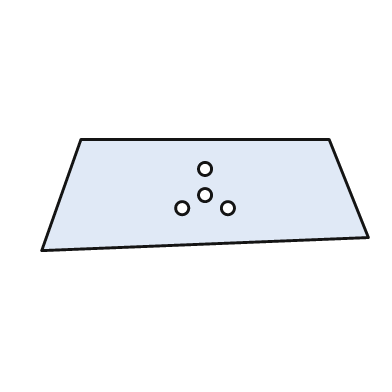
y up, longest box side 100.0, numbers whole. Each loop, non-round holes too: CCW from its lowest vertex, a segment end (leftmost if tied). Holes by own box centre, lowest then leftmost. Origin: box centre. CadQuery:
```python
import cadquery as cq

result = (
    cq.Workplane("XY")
    .moveTo(-50.0, -17.0)
    .lineTo(50.0, -13.0)
    .lineTo(38.0, 17.0)
    .lineTo(-38.0, 17.0)
    .close()
    .moveTo(-7.0, -4.0)
    .circle(2.0)
    .moveTo(7.0, -4.0)
    .circle(2.0)
    .moveTo(0.0, 0.0)
    .circle(2.0)
    .moveTo(0.0, 8.0)
    .circle(2.0)
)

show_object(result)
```